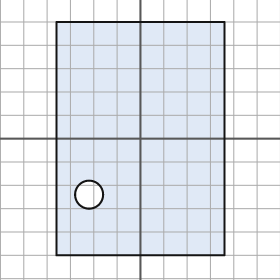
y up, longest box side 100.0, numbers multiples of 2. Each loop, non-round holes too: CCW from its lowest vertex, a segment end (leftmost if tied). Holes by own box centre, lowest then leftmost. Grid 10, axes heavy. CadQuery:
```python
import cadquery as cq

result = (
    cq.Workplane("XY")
    .moveTo(-36.0, -50.0)
    .lineTo(36.0, -50.0)
    .lineTo(36.0, 50.0)
    .lineTo(-36.0, 50.0)
    .close()
    .moveTo(-22.0, -24.0)
    .circle(6.0)
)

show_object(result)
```